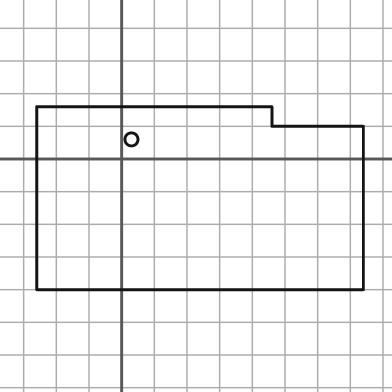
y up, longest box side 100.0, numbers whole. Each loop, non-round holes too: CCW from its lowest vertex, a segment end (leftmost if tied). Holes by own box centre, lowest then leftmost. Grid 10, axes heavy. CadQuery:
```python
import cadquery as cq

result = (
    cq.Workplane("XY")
    .moveTo(-26.0, -40.0)
    .lineTo(74.0, -40.0)
    .lineTo(74.0, 10.0)
    .lineTo(46.0, 10.0)
    .lineTo(46.0, 16.0)
    .lineTo(-26.0, 16.0)
    .close()
    .moveTo(3.0, 6.0)
    .circle(2.0)
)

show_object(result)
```